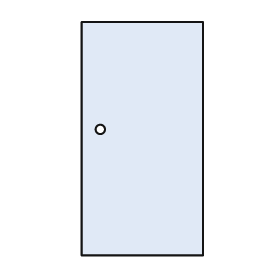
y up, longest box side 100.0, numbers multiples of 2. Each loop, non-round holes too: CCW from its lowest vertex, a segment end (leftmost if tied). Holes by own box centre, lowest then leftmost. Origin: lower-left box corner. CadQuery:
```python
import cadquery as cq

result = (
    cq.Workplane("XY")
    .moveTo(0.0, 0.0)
    .lineTo(52.0, 0.0)
    .lineTo(52.0, 100.0)
    .lineTo(0.0, 100.0)
    .close()
    .moveTo(8.0, 54.0)
    .circle(2.0)
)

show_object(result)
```